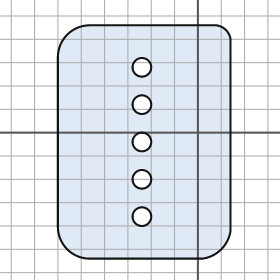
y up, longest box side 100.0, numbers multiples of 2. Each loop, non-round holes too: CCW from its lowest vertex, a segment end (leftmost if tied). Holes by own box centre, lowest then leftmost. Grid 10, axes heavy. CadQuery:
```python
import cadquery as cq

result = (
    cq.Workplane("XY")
    .moveTo(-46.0, -54.0)
    .lineTo(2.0, -54.0)
    .threePointArc((10.0, -50.0), (14.0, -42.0))
    .lineTo(14.0, 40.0)
    .threePointArc((12.0, 44.0), (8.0, 46.0))
    .lineTo(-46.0, 46.0)
    .threePointArc((-56.0, 42.0), (-60.0, 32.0))
    .lineTo(-60.0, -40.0)
    .threePointArc((-56.0, -50.0), (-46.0, -54.0))
    .close()
    .moveTo(-24.0, -36.0)
    .circle(4.0)
    .moveTo(-24.0, -20.0)
    .circle(4.0)
    .moveTo(-24.0, -4.0)
    .circle(4.0)
    .moveTo(-24.0, 12.0)
    .circle(4.0)
    .moveTo(-24.0, 28.0)
    .circle(4.0)
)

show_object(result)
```